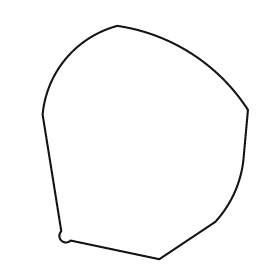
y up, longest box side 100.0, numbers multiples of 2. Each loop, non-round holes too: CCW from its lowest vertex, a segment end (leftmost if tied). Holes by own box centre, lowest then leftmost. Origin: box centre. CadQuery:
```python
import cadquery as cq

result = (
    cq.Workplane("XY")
    .moveTo(6.0, -50.0)
    .lineTo(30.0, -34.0)
    .threePointArc((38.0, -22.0), (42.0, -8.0))
    .lineTo(44.0, 14.0)
    .threePointArc((20.0, 38.0), (-12.0, 50.0))
    .threePointArc((-34.0, 36.0), (-44.0, 12.0))
    .lineTo(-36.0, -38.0)
    .threePointArc((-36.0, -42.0), (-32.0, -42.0))
    .close()
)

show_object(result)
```